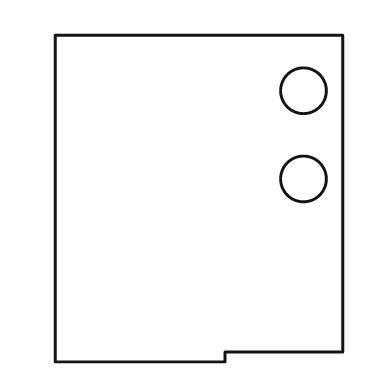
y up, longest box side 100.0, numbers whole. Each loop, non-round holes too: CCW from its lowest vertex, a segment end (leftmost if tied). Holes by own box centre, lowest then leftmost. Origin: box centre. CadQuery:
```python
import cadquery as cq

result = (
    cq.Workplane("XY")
    .moveTo(-44.0, -50.0)
    .lineTo(8.0, -50.0)
    .lineTo(8.0, -47.0)
    .lineTo(44.0, -47.0)
    .lineTo(44.0, 50.0)
    .lineTo(-44.0, 50.0)
    .close()
    .moveTo(32.0, 6.0)
    .circle(7.0)
    .moveTo(32.0, 33.0)
    .circle(7.0)
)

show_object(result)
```